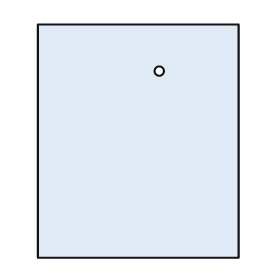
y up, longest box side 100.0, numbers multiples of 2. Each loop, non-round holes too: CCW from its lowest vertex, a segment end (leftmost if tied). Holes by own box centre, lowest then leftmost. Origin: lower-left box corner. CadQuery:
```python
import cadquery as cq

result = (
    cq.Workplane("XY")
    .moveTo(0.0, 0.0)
    .lineTo(86.0, 0.0)
    .lineTo(86.0, 100.0)
    .lineTo(0.0, 100.0)
    .close()
    .moveTo(52.0, 80.0)
    .circle(2.0)
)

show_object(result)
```